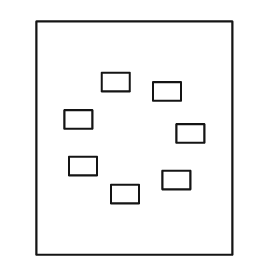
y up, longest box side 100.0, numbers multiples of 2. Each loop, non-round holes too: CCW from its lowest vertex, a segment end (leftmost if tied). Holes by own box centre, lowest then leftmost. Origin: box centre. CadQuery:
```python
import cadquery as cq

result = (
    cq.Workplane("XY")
    .moveTo(-42.0, -50.0)
    .lineTo(42.0, -50.0)
    .lineTo(42.0, 50.0)
    .lineTo(-42.0, 50.0)
    .close()
    .moveTo(-10.0, -28.0)
    .lineTo(2.0, -28.0)
    .lineTo(2.0, -20.0)
    .lineTo(-10.0, -20.0)
    .close()
    .moveTo(12.0, -22.0)
    .lineTo(24.0, -22.0)
    .lineTo(24.0, -14.0)
    .lineTo(12.0, -14.0)
    .close()
    .moveTo(-28.0, -16.0)
    .lineTo(-16.0, -16.0)
    .lineTo(-16.0, -8.0)
    .lineTo(-28.0, -8.0)
    .close()
    .moveTo(18.0, -2.0)
    .lineTo(30.0, -2.0)
    .lineTo(30.0, 6.0)
    .lineTo(18.0, 6.0)
    .close()
    .moveTo(-30.0, 4.0)
    .lineTo(-18.0, 4.0)
    .lineTo(-18.0, 12.0)
    .lineTo(-30.0, 12.0)
    .close()
    .moveTo(8.0, 16.0)
    .lineTo(20.0, 16.0)
    .lineTo(20.0, 24.0)
    .lineTo(8.0, 24.0)
    .close()
    .moveTo(-14.0, 20.0)
    .lineTo(-2.0, 20.0)
    .lineTo(-2.0, 28.0)
    .lineTo(-14.0, 28.0)
    .close()
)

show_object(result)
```